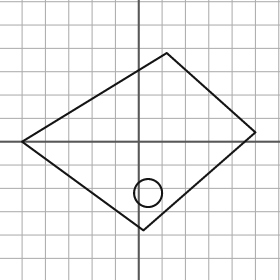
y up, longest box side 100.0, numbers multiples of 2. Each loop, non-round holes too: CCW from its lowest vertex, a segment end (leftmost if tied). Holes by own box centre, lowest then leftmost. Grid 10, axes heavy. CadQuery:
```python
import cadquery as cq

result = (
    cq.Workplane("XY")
    .moveTo(2.0, -38.0)
    .lineTo(50.0, 4.0)
    .lineTo(12.0, 38.0)
    .lineTo(-50.0, 0.0)
    .close()
    .moveTo(4.0, -22.0)
    .circle(6.0)
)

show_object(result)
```